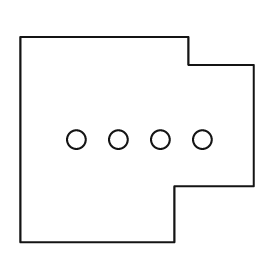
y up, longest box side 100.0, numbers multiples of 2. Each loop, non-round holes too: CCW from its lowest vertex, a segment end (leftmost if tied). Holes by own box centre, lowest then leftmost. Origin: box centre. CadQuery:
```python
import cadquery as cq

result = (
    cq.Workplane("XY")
    .moveTo(-50.0, -44.0)
    .lineTo(16.0, -44.0)
    .lineTo(16.0, -20.0)
    .lineTo(50.0, -20.0)
    .lineTo(50.0, 32.0)
    .lineTo(22.0, 32.0)
    .lineTo(22.0, 44.0)
    .lineTo(-50.0, 44.0)
    .close()
    .moveTo(-26.0, 0.0)
    .circle(4.0)
    .moveTo(-8.0, 0.0)
    .circle(4.0)
    .moveTo(10.0, 0.0)
    .circle(4.0)
    .moveTo(28.0, 0.0)
    .circle(4.0)
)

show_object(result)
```